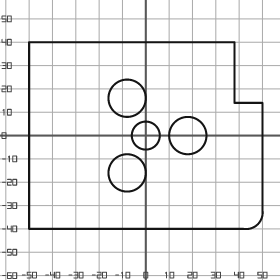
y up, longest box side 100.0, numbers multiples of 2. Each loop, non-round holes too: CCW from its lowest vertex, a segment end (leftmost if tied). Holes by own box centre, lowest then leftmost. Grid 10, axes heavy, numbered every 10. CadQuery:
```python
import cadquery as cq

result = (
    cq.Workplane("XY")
    .moveTo(-50.0, -40.0)
    .lineTo(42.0, -40.0)
    .threePointArc((48.0, -38.0), (50.0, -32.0))
    .lineTo(50.0, 14.0)
    .lineTo(38.0, 14.0)
    .lineTo(38.0, 40.0)
    .lineTo(-50.0, 40.0)
    .close()
    .moveTo(-8.0, -16.0)
    .circle(8.0)
    .moveTo(0.0, 0.0)
    .circle(6.0)
    .moveTo(18.0, 0.0)
    .circle(8.0)
    .moveTo(-8.0, 16.0)
    .circle(8.0)
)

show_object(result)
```